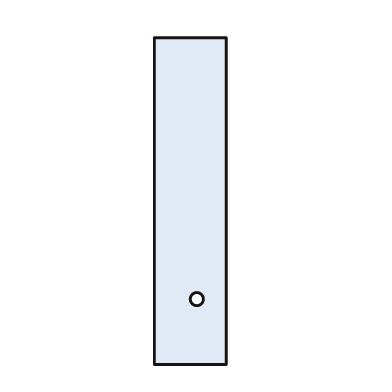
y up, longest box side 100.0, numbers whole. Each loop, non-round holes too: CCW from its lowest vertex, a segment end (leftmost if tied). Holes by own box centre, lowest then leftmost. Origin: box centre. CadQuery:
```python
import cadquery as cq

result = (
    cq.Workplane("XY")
    .moveTo(-11.0, -50.0)
    .lineTo(11.0, -50.0)
    .lineTo(11.0, 50.0)
    .lineTo(-11.0, 50.0)
    .close()
    .moveTo(2.0, -30.0)
    .circle(2.0)
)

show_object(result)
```